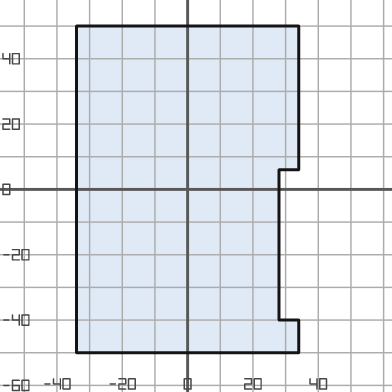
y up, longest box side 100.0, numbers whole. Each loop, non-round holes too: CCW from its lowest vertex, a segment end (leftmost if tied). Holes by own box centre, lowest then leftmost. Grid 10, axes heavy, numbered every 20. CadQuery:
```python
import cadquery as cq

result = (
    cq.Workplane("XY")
    .moveTo(-34.0, -50.0)
    .lineTo(34.0, -50.0)
    .lineTo(34.0, -40.0)
    .lineTo(28.0, -40.0)
    .lineTo(28.0, 6.0)
    .lineTo(34.0, 6.0)
    .lineTo(34.0, 50.0)
    .lineTo(-34.0, 50.0)
    .close()
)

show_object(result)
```